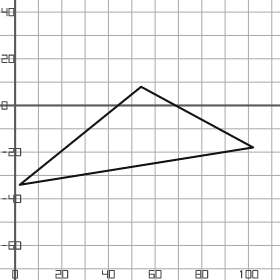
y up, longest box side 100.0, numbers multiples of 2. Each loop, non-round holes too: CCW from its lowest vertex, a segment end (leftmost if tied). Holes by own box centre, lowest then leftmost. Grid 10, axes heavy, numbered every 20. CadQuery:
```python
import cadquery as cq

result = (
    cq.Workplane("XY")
    .moveTo(2.0, -34.0)
    .lineTo(102.0, -18.0)
    .lineTo(54.0, 8.0)
    .close()
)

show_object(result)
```